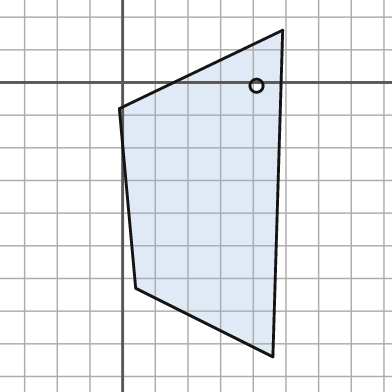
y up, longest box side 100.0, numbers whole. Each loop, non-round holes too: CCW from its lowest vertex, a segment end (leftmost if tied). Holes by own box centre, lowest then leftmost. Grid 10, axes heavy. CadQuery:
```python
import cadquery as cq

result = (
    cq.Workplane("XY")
    .moveTo(46.0, -84.0)
    .lineTo(49.0, 16.0)
    .lineTo(-1.0, -8.0)
    .lineTo(4.0, -63.0)
    .close()
    .moveTo(41.0, -1.0)
    .circle(2.0)
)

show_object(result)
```